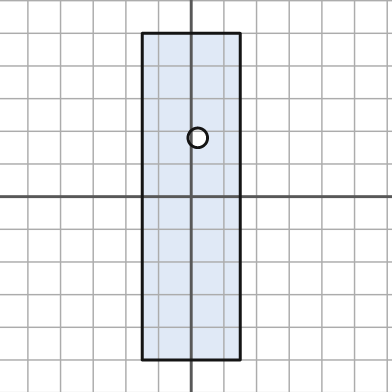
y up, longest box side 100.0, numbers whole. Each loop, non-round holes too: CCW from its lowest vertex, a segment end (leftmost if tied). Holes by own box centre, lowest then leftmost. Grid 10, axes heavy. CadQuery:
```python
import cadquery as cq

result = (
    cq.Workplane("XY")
    .moveTo(-15.0, -50.0)
    .lineTo(15.0, -50.0)
    .lineTo(15.0, 50.0)
    .lineTo(-15.0, 50.0)
    .close()
    .moveTo(2.0, 18.0)
    .circle(3.0)
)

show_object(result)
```